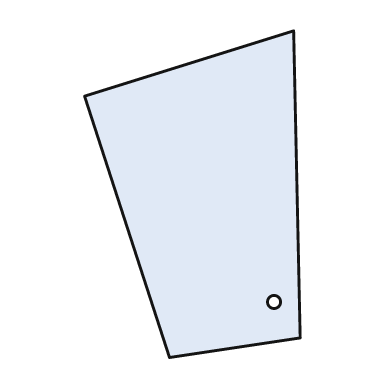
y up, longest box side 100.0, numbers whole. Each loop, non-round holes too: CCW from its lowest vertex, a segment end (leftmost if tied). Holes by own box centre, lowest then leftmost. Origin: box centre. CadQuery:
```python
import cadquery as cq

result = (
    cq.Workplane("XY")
    .moveTo(-7.0, -50.0)
    .lineTo(33.0, -44.0)
    .lineTo(31.0, 50.0)
    .lineTo(-33.0, 30.0)
    .close()
    .moveTo(25.0, -33.0)
    .circle(2.0)
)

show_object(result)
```